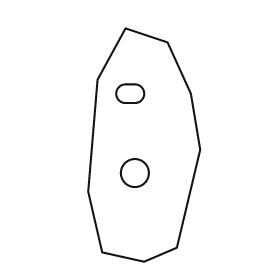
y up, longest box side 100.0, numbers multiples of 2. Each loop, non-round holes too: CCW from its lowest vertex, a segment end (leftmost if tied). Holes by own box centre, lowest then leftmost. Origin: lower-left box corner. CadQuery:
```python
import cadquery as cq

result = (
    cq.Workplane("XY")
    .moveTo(24.0, 0.0)
    .lineTo(38.0, 6.0)
    .lineTo(48.0, 48.0)
    .lineTo(44.0, 72.0)
    .lineTo(34.0, 94.0)
    .lineTo(16.0, 100.0)
    .lineTo(4.0, 78.0)
    .lineTo(0.0, 30.0)
    .lineTo(6.0, 4.0)
    .close()
    .moveTo(20.0, 38.0)
    .circle(6.0)
    .moveTo(16.0, 68.0)
    .lineTo(20.0, 68.0)
    .threePointArc((24.0, 72.0), (20.0, 76.0))
    .lineTo(16.0, 76.0)
    .threePointArc((12.0, 72.0), (16.0, 68.0))
    .close()
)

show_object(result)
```